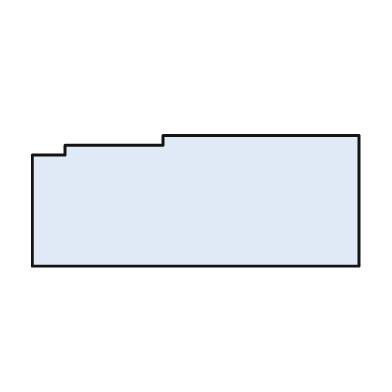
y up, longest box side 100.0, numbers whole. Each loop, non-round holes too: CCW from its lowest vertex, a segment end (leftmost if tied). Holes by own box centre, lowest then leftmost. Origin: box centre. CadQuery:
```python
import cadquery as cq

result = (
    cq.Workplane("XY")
    .moveTo(-50.0, -20.0)
    .lineTo(50.0, -20.0)
    .lineTo(50.0, 20.0)
    .lineTo(-10.0, 20.0)
    .lineTo(-10.0, 17.0)
    .lineTo(-40.0, 17.0)
    .lineTo(-40.0, 14.0)
    .lineTo(-50.0, 14.0)
    .close()
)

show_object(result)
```